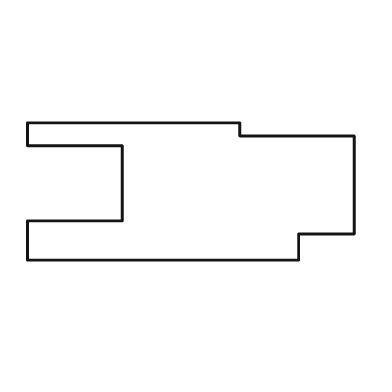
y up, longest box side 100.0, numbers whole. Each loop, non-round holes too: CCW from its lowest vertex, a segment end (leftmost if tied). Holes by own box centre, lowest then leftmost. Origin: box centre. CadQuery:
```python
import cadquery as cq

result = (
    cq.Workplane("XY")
    .moveTo(-50.0, -21.0)
    .lineTo(33.0, -21.0)
    .lineTo(33.0, -13.0)
    .lineTo(50.0, -13.0)
    .lineTo(50.0, 17.0)
    .lineTo(15.0, 17.0)
    .lineTo(15.0, 21.0)
    .lineTo(-50.0, 21.0)
    .lineTo(-50.0, 14.0)
    .lineTo(-21.0, 14.0)
    .lineTo(-21.0, -9.0)
    .lineTo(-50.0, -9.0)
    .close()
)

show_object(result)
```